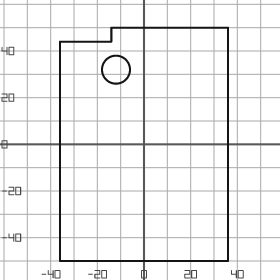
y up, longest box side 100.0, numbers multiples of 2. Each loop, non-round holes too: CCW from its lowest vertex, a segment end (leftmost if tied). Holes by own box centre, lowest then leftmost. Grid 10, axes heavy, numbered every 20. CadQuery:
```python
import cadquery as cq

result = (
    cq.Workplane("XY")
    .moveTo(-36.0, -50.0)
    .lineTo(36.0, -50.0)
    .lineTo(36.0, 50.0)
    .lineTo(-14.0, 50.0)
    .lineTo(-14.0, 44.0)
    .lineTo(-36.0, 44.0)
    .close()
    .moveTo(-12.0, 32.0)
    .circle(6.0)
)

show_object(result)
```